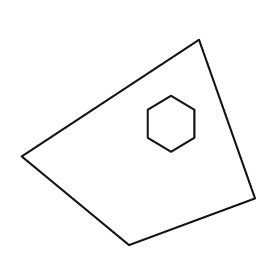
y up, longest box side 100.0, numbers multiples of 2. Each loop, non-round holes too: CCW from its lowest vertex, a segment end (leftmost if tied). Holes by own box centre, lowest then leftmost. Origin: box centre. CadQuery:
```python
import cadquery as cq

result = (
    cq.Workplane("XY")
    .moveTo(-4.0, -44.0)
    .lineTo(50.0, -24.0)
    .lineTo(26.0, 44.0)
    .lineTo(-50.0, -6.0)
    .close()
    .moveTo(14.0, -4.0)
    .lineTo(24.0, 2.0)
    .lineTo(24.0, 14.0)
    .lineTo(14.0, 20.0)
    .lineTo(4.0, 14.0)
    .lineTo(4.0, 2.0)
    .close()
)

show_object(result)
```